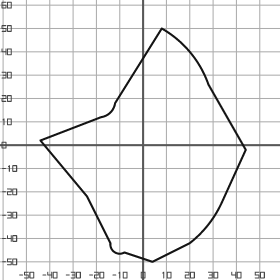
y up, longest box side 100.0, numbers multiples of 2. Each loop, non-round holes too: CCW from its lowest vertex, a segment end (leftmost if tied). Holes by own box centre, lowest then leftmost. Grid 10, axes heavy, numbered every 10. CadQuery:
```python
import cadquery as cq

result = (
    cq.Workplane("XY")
    .moveTo(4.0, -50.0)
    .lineTo(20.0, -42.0)
    .threePointArc((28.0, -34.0), (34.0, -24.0))
    .lineTo(44.0, -2.0)
    .lineTo(28.0, 26.0)
    .threePointArc((20.0, 40.0), (8.0, 50.0))
    .lineTo(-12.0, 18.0)
    .threePointArc((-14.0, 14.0), (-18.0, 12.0))
    .lineTo(-44.0, 2.0)
    .lineTo(-24.0, -22.0)
    .lineTo(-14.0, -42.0)
    .threePointArc((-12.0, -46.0), (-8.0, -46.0))
    .close()
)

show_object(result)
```